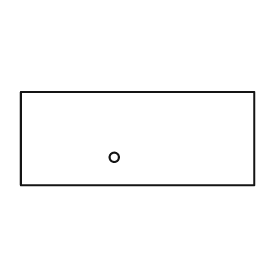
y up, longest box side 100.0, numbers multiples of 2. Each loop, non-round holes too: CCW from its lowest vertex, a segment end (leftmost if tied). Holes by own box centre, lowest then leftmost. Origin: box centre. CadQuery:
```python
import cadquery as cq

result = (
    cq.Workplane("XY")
    .moveTo(-50.0, -20.0)
    .lineTo(50.0, -20.0)
    .lineTo(50.0, 20.0)
    .lineTo(-50.0, 20.0)
    .close()
    .moveTo(-10.0, -8.0)
    .circle(2.0)
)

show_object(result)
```